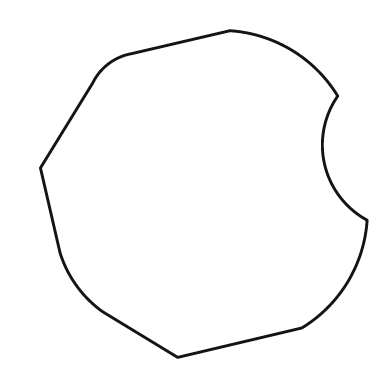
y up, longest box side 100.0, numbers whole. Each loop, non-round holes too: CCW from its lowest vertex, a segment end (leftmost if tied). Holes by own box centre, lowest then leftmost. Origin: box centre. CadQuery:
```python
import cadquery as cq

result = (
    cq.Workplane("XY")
    .moveTo(-8.0, -50.0)
    .lineTo(30.0, -41.0)
    .threePointArc((44.0, -27.0), (50.0, -8.0))
    .threePointArc((37.0, 9.0), (41.0, 30.0))
    .threePointArc((27.0, 44.0), (8.0, 50.0))
    .lineTo(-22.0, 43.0)
    .threePointArc((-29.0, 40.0), (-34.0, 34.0))
    .lineTo(-50.0, 8.0)
    .lineTo(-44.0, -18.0)
    .threePointArc((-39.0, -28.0), (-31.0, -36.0))
    .close()
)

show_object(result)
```